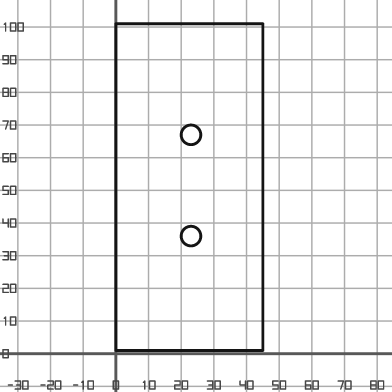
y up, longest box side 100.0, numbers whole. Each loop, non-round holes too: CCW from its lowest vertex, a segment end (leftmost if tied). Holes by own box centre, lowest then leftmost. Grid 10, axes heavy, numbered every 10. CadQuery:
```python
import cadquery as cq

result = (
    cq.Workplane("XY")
    .moveTo(0.0, 1.0)
    .lineTo(45.0, 1.0)
    .lineTo(45.0, 101.0)
    .lineTo(0.0, 101.0)
    .close()
    .moveTo(23.0, 36.0)
    .circle(3.0)
    .moveTo(23.0, 67.0)
    .circle(3.0)
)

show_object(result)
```